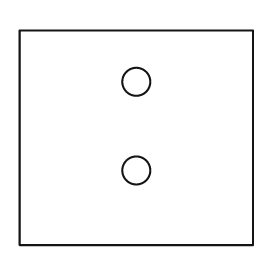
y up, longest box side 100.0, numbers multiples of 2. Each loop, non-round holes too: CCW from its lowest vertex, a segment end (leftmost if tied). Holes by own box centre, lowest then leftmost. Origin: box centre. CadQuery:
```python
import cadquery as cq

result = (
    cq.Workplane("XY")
    .moveTo(-50.0, -46.0)
    .lineTo(50.0, -46.0)
    .lineTo(50.0, 46.0)
    .lineTo(-50.0, 46.0)
    .close()
    .moveTo(0.0, -14.0)
    .circle(6.0)
    .moveTo(0.0, 24.0)
    .circle(6.0)
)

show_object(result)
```